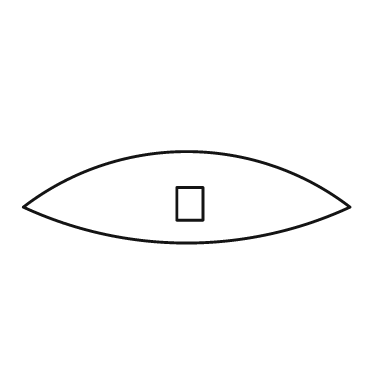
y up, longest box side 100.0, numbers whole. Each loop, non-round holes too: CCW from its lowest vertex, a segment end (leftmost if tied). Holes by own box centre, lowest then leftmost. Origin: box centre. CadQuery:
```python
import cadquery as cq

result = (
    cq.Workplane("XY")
    .moveTo(-50.0, -3.0)
    .threePointArc((0.0, -14.0), (50.0, -3.0))
    .threePointArc((0.0, 14.0), (-50.0, -3.0))
    .close()
    .moveTo(-3.0, -7.0)
    .lineTo(5.0, -7.0)
    .lineTo(5.0, 3.0)
    .lineTo(-3.0, 3.0)
    .close()
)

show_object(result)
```